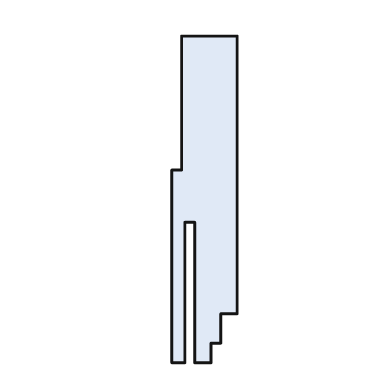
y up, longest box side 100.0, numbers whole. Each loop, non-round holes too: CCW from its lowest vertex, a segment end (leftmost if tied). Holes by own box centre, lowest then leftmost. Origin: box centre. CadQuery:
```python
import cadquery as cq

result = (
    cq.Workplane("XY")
    .moveTo(-10.0, -50.0)
    .lineTo(-6.0, -50.0)
    .lineTo(-6.0, -7.0)
    .lineTo(-3.0, -7.0)
    .lineTo(-3.0, -50.0)
    .lineTo(2.0, -50.0)
    .lineTo(2.0, -44.0)
    .lineTo(5.0, -44.0)
    .lineTo(5.0, -35.0)
    .lineTo(10.0, -35.0)
    .lineTo(10.0, 50.0)
    .lineTo(-7.0, 50.0)
    .lineTo(-7.0, 9.0)
    .lineTo(-10.0, 9.0)
    .close()
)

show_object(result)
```